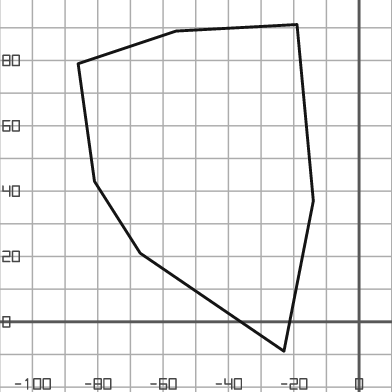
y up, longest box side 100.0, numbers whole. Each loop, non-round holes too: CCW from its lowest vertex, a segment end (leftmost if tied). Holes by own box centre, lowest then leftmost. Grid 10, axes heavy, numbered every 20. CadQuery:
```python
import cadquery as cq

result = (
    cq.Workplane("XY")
    .moveTo(-23.0, -9.0)
    .lineTo(-14.0, 37.0)
    .lineTo(-19.0, 91.0)
    .lineTo(-56.0, 89.0)
    .lineTo(-86.0, 79.0)
    .lineTo(-81.0, 43.0)
    .lineTo(-67.0, 21.0)
    .close()
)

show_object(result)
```